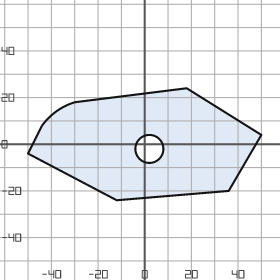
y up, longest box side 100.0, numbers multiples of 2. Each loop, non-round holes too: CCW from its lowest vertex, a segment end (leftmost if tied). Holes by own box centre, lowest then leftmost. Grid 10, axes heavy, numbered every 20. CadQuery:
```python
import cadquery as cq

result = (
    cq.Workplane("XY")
    .moveTo(-12.0, -24.0)
    .lineTo(36.0, -20.0)
    .lineTo(50.0, 4.0)
    .lineTo(18.0, 24.0)
    .lineTo(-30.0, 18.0)
    .threePointArc((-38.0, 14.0), (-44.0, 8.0))
    .lineTo(-50.0, -4.0)
    .close()
    .moveTo(2.0, -2.0)
    .circle(6.0)
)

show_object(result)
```